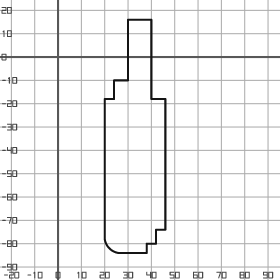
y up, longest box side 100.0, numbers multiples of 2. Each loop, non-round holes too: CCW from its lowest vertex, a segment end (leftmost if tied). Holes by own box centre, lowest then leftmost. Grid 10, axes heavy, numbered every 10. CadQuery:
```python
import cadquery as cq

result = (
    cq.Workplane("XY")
    .moveTo(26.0, -84.0)
    .lineTo(38.0, -84.0)
    .lineTo(38.0, -80.0)
    .lineTo(42.0, -80.0)
    .lineTo(42.0, -74.0)
    .lineTo(46.0, -74.0)
    .lineTo(46.0, -18.0)
    .lineTo(40.0, -18.0)
    .lineTo(40.0, 16.0)
    .lineTo(30.0, 16.0)
    .lineTo(30.0, -10.0)
    .lineTo(24.0, -10.0)
    .lineTo(24.0, -18.0)
    .lineTo(20.0, -18.0)
    .lineTo(20.0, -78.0)
    .threePointArc((22.0, -82.0), (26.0, -84.0))
    .close()
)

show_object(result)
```